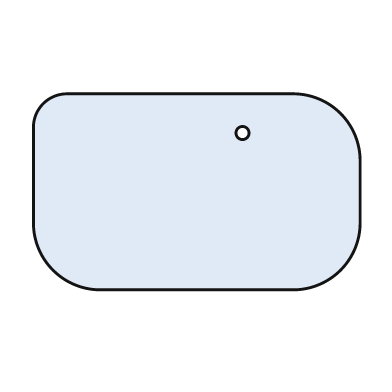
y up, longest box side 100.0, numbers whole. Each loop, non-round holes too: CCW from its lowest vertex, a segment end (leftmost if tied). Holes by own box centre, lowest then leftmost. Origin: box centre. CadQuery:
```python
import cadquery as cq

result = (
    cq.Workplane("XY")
    .moveTo(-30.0, -30.0)
    .lineTo(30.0, -30.0)
    .threePointArc((44.0, -24.0), (50.0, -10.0))
    .lineTo(50.0, 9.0)
    .threePointArc((44.0, 24.0), (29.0, 30.0))
    .lineTo(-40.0, 30.0)
    .threePointArc((-47.0, 27.0), (-50.0, 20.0))
    .lineTo(-50.0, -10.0)
    .threePointArc((-44.0, -24.0), (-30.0, -30.0))
    .close()
    .moveTo(14.0, 18.0)
    .circle(2.0)
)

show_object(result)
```